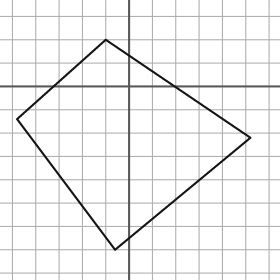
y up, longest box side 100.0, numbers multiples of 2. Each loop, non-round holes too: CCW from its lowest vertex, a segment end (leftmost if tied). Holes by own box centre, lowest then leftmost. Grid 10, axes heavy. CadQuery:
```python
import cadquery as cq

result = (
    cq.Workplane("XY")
    .moveTo(-6.0, -70.0)
    .lineTo(52.0, -22.0)
    .lineTo(-10.0, 20.0)
    .lineTo(-48.0, -14.0)
    .close()
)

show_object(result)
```